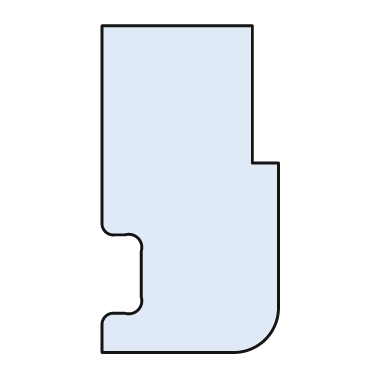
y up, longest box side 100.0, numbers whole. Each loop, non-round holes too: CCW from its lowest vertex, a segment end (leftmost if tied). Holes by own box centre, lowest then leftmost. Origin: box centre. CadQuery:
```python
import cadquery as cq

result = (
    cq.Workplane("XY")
    .moveTo(-27.0, -50.0)
    .lineTo(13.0, -50.0)
    .threePointArc((23.0, -46.0), (27.0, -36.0))
    .lineTo(27.0, 8.0)
    .lineTo(19.0, 8.0)
    .lineTo(19.0, 50.0)
    .lineTo(-27.0, 50.0)
    .lineTo(-27.0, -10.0)
    .threePointArc((-26.0, -13.0), (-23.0, -14.0))
    .lineTo(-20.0, -14.0)
    .threePointArc((-16.0, -15.0), (-15.0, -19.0))
    .lineTo(-15.0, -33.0)
    .threePointArc((-16.0, -37.0), (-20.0, -38.0))
    .lineTo(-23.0, -38.0)
    .threePointArc((-26.0, -39.0), (-27.0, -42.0))
    .close()
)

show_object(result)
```